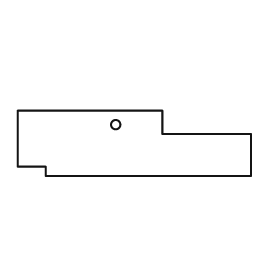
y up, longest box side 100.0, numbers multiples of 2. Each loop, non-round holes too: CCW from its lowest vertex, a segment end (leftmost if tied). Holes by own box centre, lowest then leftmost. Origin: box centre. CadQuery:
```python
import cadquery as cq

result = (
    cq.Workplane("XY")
    .moveTo(-38.0, -14.0)
    .lineTo(50.0, -14.0)
    .lineTo(50.0, 4.0)
    .lineTo(12.0, 4.0)
    .lineTo(12.0, 14.0)
    .lineTo(-50.0, 14.0)
    .lineTo(-50.0, -10.0)
    .lineTo(-38.0, -10.0)
    .close()
    .moveTo(-8.0, 8.0)
    .circle(2.0)
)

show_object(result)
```